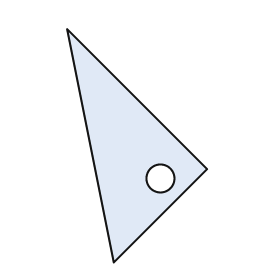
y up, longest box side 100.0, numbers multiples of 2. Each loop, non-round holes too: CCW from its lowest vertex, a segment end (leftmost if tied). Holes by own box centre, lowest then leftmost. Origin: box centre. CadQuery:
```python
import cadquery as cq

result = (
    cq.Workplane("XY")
    .moveTo(-10.0, -50.0)
    .lineTo(30.0, -10.0)
    .lineTo(-30.0, 50.0)
    .close()
    .moveTo(10.0, -14.0)
    .circle(6.0)
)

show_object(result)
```